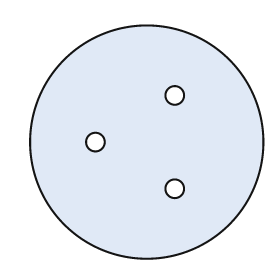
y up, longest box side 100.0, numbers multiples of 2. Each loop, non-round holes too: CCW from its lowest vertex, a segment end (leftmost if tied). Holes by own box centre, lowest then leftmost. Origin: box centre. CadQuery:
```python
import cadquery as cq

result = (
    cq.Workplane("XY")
    .moveTo(0.0, 0.0)
    .circle(50.0)
    .moveTo(12.0, -20.0)
    .circle(4.0)
    .moveTo(-22.0, 0.0)
    .circle(4.0)
    .moveTo(12.0, 20.0)
    .circle(4.0)
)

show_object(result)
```